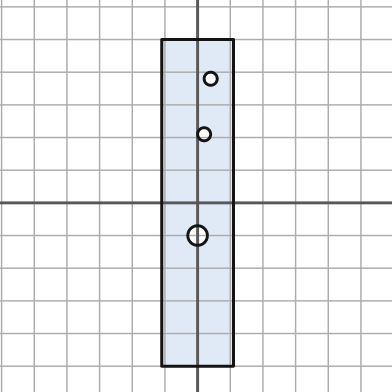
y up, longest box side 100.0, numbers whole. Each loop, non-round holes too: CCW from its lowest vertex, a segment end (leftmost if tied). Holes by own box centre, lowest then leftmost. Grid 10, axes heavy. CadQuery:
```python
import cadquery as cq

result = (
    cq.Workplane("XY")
    .moveTo(-11.0, -50.0)
    .lineTo(11.0, -50.0)
    .lineTo(11.0, 50.0)
    .lineTo(-11.0, 50.0)
    .close()
    .moveTo(0.0, -10.0)
    .circle(3.0)
    .moveTo(2.0, 21.0)
    .circle(2.0)
    .moveTo(4.0, 38.0)
    .circle(2.0)
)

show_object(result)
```